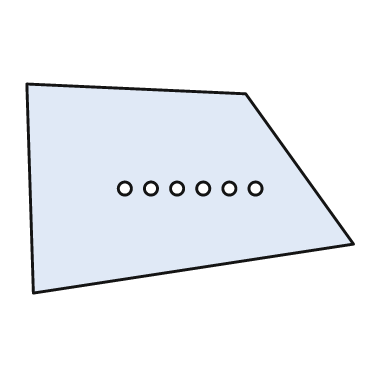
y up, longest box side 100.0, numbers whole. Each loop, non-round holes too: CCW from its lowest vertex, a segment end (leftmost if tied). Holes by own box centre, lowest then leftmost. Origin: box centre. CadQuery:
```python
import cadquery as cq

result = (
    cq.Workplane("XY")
    .moveTo(-48.0, -32.0)
    .lineTo(50.0, -17.0)
    .lineTo(17.0, 29.0)
    .lineTo(-50.0, 32.0)
    .close()
    .moveTo(-20.0, 0.0)
    .circle(2.0)
    .moveTo(-12.0, 0.0)
    .circle(2.0)
    .moveTo(-4.0, 0.0)
    .circle(2.0)
    .moveTo(4.0, 0.0)
    .circle(2.0)
    .moveTo(12.0, 0.0)
    .circle(2.0)
    .moveTo(20.0, 0.0)
    .circle(2.0)
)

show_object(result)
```